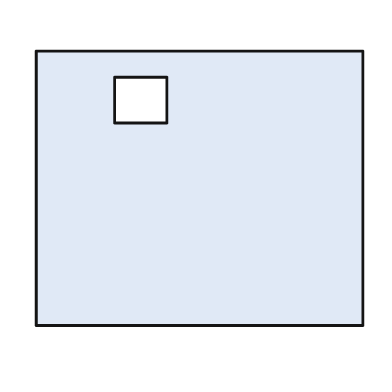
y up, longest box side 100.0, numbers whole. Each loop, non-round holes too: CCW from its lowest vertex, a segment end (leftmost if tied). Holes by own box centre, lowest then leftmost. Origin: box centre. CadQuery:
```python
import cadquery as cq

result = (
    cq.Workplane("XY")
    .moveTo(-50.0, -42.0)
    .lineTo(50.0, -42.0)
    .lineTo(50.0, 42.0)
    .lineTo(-50.0, 42.0)
    .close()
    .moveTo(-26.0, 20.0)
    .lineTo(-10.0, 20.0)
    .lineTo(-10.0, 34.0)
    .lineTo(-26.0, 34.0)
    .close()
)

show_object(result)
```